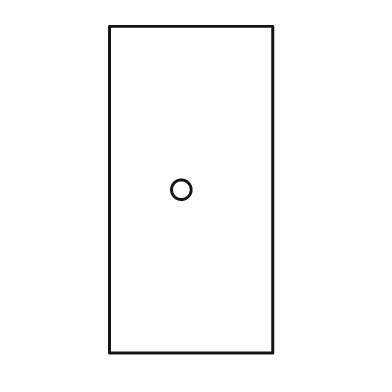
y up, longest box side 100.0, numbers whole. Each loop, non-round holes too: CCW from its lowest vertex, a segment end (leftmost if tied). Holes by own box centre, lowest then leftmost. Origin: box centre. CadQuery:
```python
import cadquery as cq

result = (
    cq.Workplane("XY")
    .moveTo(-25.0, -50.0)
    .lineTo(25.0, -50.0)
    .lineTo(25.0, 50.0)
    .lineTo(-25.0, 50.0)
    .close()
    .moveTo(-3.0, 0.0)
    .circle(3.0)
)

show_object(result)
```